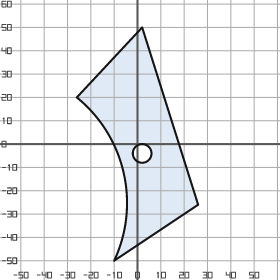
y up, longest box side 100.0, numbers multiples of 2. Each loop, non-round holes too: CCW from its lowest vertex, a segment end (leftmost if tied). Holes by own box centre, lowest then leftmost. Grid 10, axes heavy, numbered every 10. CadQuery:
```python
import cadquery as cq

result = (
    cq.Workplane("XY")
    .moveTo(-10.0, -50.0)
    .lineTo(26.0, -26.0)
    .lineTo(2.0, 50.0)
    .lineTo(-26.0, 20.0)
    .threePointArc((-6.0, -12.0), (-10.0, -50.0))
    .close()
    .moveTo(2.0, -4.0)
    .circle(4.0)
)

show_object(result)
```